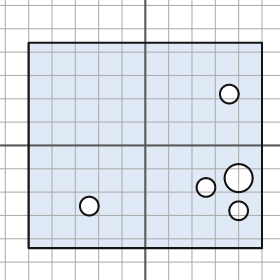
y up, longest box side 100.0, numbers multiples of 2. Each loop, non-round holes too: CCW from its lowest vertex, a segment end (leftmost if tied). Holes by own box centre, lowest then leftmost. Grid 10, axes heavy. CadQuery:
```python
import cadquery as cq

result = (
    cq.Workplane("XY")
    .moveTo(-50.0, -44.0)
    .lineTo(50.0, -44.0)
    .lineTo(50.0, 44.0)
    .lineTo(-50.0, 44.0)
    .close()
    .moveTo(40.0, -28.0)
    .circle(4.0)
    .moveTo(-24.0, -26.0)
    .circle(4.0)
    .moveTo(26.0, -18.0)
    .circle(4.0)
    .moveTo(40.0, -14.0)
    .circle(6.0)
    .moveTo(36.0, 22.0)
    .circle(4.0)
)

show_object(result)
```